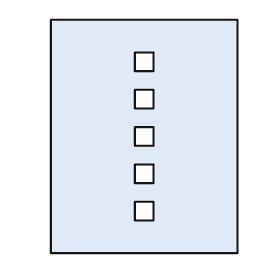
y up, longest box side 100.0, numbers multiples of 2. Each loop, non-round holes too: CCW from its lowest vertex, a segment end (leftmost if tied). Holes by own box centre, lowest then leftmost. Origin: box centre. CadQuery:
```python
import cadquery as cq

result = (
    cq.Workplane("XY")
    .moveTo(-40.0, -50.0)
    .lineTo(40.0, -50.0)
    .lineTo(40.0, 50.0)
    .lineTo(-40.0, 50.0)
    .close()
    .moveTo(-4.0, -36.0)
    .lineTo(4.0, -36.0)
    .lineTo(4.0, -28.0)
    .lineTo(-4.0, -28.0)
    .close()
    .moveTo(-4.0, -20.0)
    .lineTo(4.0, -20.0)
    .lineTo(4.0, -12.0)
    .lineTo(-4.0, -12.0)
    .close()
    .moveTo(-4.0, -4.0)
    .lineTo(4.0, -4.0)
    .lineTo(4.0, 4.0)
    .lineTo(-4.0, 4.0)
    .close()
    .moveTo(-4.0, 12.0)
    .lineTo(4.0, 12.0)
    .lineTo(4.0, 20.0)
    .lineTo(-4.0, 20.0)
    .close()
    .moveTo(-4.0, 28.0)
    .lineTo(4.0, 28.0)
    .lineTo(4.0, 36.0)
    .lineTo(-4.0, 36.0)
    .close()
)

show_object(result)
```